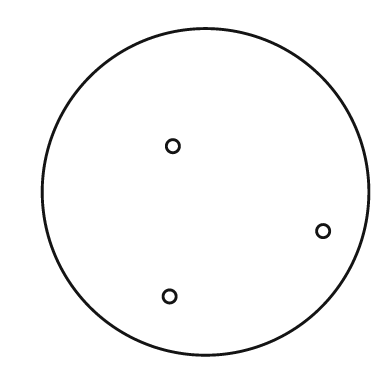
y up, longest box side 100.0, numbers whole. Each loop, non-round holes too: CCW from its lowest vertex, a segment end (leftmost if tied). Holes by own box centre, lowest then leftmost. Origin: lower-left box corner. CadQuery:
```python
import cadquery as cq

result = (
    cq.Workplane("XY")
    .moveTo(50.0, 50.0)
    .circle(50.0)
    .moveTo(39.0, 18.0)
    .circle(2.0)
    .moveTo(86.0, 38.0)
    .circle(2.0)
    .moveTo(40.0, 64.0)
    .circle(2.0)
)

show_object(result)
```